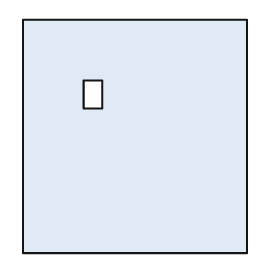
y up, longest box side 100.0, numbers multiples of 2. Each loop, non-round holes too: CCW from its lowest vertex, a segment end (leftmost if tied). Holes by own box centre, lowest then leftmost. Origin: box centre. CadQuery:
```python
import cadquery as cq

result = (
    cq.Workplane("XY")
    .moveTo(-48.0, -50.0)
    .lineTo(48.0, -50.0)
    .lineTo(48.0, 50.0)
    .lineTo(-48.0, 50.0)
    .close()
    .moveTo(-22.0, 12.0)
    .lineTo(-14.0, 12.0)
    .lineTo(-14.0, 24.0)
    .lineTo(-22.0, 24.0)
    .close()
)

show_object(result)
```